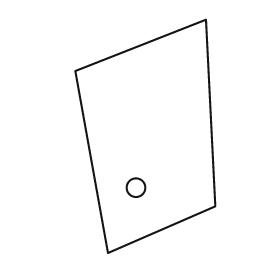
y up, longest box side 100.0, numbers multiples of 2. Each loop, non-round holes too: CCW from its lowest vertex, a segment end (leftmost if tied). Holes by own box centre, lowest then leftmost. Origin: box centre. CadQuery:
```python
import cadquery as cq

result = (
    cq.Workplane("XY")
    .moveTo(-16.0, -50.0)
    .lineTo(30.0, -30.0)
    .lineTo(26.0, 50.0)
    .lineTo(-30.0, 28.0)
    .close()
    .moveTo(-4.0, -22.0)
    .circle(4.0)
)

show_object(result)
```